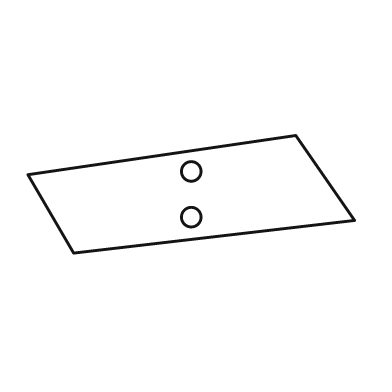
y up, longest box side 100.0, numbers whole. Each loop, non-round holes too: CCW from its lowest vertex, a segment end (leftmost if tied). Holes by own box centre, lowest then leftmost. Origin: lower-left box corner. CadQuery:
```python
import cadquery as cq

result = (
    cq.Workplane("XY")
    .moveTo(14.0, 0.0)
    .lineTo(100.0, 10.0)
    .lineTo(82.0, 36.0)
    .lineTo(0.0, 24.0)
    .close()
    .moveTo(50.0, 11.0)
    .circle(3.0)
    .moveTo(50.0, 25.0)
    .circle(3.0)
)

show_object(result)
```